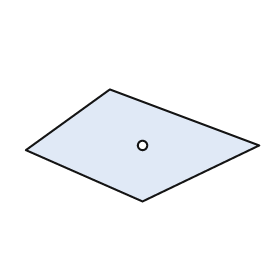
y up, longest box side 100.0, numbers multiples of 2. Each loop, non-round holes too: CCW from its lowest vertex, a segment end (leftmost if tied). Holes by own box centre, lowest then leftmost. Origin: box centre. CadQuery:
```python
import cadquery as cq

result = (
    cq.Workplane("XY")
    .moveTo(0.0, -24.0)
    .lineTo(50.0, 0.0)
    .lineTo(-14.0, 24.0)
    .lineTo(-50.0, -2.0)
    .close()
    .moveTo(0.0, 0.0)
    .circle(2.0)
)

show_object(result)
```